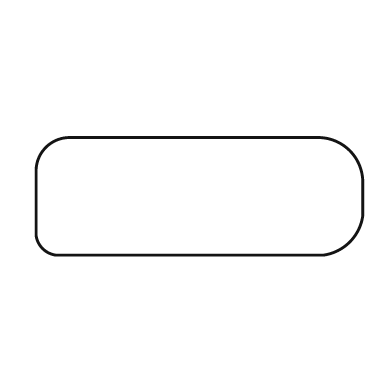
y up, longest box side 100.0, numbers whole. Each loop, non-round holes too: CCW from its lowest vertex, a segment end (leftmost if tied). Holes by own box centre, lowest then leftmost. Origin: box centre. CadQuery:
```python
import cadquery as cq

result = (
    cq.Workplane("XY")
    .moveTo(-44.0, -18.0)
    .lineTo(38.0, -18.0)
    .threePointArc((46.0, -14.0), (50.0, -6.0))
    .lineTo(50.0, 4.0)
    .threePointArc((46.0, 14.0), (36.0, 18.0))
    .lineTo(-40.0, 18.0)
    .threePointArc((-47.0, 15.0), (-50.0, 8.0))
    .lineTo(-50.0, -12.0)
    .threePointArc((-48.0, -16.0), (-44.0, -18.0))
    .close()
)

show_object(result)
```